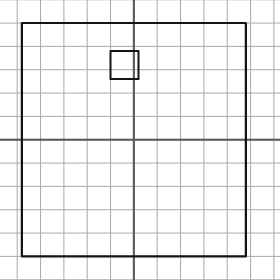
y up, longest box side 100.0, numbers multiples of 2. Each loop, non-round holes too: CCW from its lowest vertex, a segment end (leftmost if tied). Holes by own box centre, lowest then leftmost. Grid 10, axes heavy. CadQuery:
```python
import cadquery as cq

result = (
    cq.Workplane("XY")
    .moveTo(-48.0, -50.0)
    .lineTo(48.0, -50.0)
    .lineTo(48.0, 50.0)
    .lineTo(-48.0, 50.0)
    .close()
    .moveTo(-10.0, 26.0)
    .lineTo(2.0, 26.0)
    .lineTo(2.0, 38.0)
    .lineTo(-10.0, 38.0)
    .close()
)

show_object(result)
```